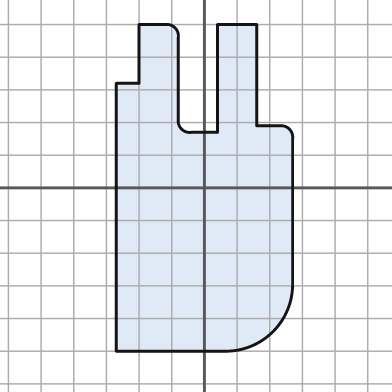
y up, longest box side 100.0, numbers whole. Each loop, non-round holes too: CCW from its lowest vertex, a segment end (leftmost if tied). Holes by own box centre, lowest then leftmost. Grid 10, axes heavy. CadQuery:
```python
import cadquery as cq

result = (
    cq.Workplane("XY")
    .moveTo(-27.0, -50.0)
    .lineTo(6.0, -50.0)
    .threePointArc((21.0, -44.0), (27.0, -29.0))
    .lineTo(27.0, 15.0)
    .threePointArc((26.0, 18.0), (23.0, 19.0))
    .lineTo(16.0, 19.0)
    .lineTo(16.0, 50.0)
    .lineTo(4.0, 50.0)
    .lineTo(4.0, 17.0)
    .lineTo(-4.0, 17.0)
    .threePointArc((-7.0, 18.0), (-8.0, 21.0))
    .lineTo(-8.0, 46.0)
    .threePointArc((-9.0, 49.0), (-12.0, 50.0))
    .lineTo(-20.0, 50.0)
    .lineTo(-20.0, 32.0)
    .lineTo(-27.0, 32.0)
    .close()
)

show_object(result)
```